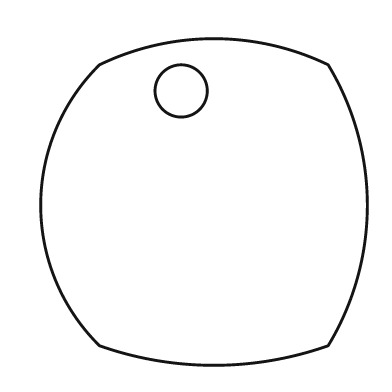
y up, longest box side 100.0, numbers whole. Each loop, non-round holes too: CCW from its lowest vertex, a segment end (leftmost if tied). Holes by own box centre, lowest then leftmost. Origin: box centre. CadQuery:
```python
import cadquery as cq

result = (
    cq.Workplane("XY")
    .moveTo(-32.0, -44.0)
    .threePointArc((3.0, -50.0), (38.0, -44.0))
    .threePointArc((50.0, -1.0), (38.0, 42.0))
    .threePointArc((3.0, 50.0), (-32.0, 42.0))
    .threePointArc((-50.0, -1.0), (-32.0, -44.0))
    .close()
    .moveTo(-7.0, 34.0)
    .circle(8.0)
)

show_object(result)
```